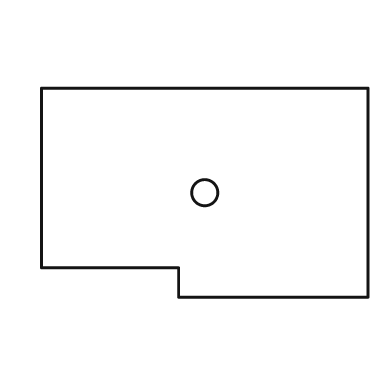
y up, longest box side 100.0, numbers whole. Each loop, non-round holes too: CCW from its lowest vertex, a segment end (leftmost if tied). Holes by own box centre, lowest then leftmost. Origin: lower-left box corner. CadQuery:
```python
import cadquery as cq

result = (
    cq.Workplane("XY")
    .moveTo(42.0, 0.0)
    .lineTo(100.0, 0.0)
    .lineTo(100.0, 64.0)
    .lineTo(0.0, 64.0)
    .lineTo(0.0, 9.0)
    .lineTo(42.0, 9.0)
    .close()
    .moveTo(50.0, 32.0)
    .circle(4.0)
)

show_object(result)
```